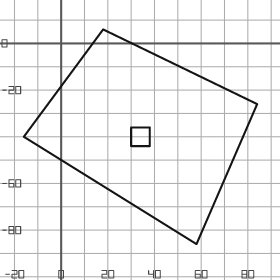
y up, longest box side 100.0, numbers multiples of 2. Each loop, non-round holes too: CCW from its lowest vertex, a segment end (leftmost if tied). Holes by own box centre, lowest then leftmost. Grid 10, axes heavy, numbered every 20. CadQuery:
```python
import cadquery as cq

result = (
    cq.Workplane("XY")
    .moveTo(58.0, -86.0)
    .lineTo(84.0, -26.0)
    .lineTo(18.0, 6.0)
    .lineTo(-16.0, -40.0)
    .close()
    .moveTo(30.0, -44.0)
    .lineTo(38.0, -44.0)
    .lineTo(38.0, -36.0)
    .lineTo(30.0, -36.0)
    .close()
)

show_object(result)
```